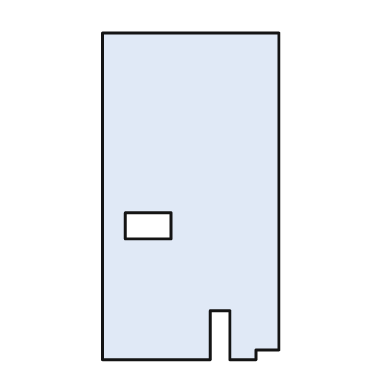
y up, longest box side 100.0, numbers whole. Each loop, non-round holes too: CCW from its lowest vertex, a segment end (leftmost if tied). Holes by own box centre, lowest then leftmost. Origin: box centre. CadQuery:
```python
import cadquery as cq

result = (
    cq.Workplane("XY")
    .moveTo(-27.0, -50.0)
    .lineTo(6.0, -50.0)
    .lineTo(6.0, -35.0)
    .lineTo(12.0, -35.0)
    .lineTo(12.0, -50.0)
    .lineTo(20.0, -50.0)
    .lineTo(20.0, -47.0)
    .lineTo(27.0, -47.0)
    .lineTo(27.0, 50.0)
    .lineTo(-27.0, 50.0)
    .close()
    .moveTo(-20.0, -13.0)
    .lineTo(-6.0, -13.0)
    .lineTo(-6.0, -5.0)
    .lineTo(-20.0, -5.0)
    .close()
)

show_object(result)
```